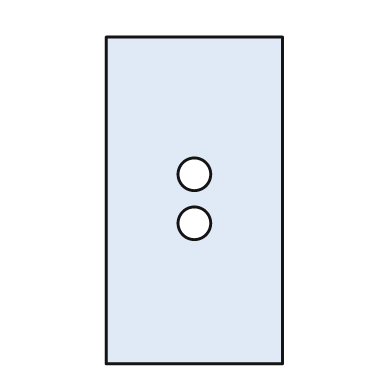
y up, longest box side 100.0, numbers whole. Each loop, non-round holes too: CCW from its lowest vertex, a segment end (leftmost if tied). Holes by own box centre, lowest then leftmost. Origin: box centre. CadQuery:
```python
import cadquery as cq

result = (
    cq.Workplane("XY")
    .moveTo(-27.0, -50.0)
    .lineTo(27.0, -50.0)
    .lineTo(27.0, 50.0)
    .lineTo(-27.0, 50.0)
    .close()
    .moveTo(0.0, -7.0)
    .circle(5.0)
    .moveTo(0.0, 8.0)
    .circle(5.0)
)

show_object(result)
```